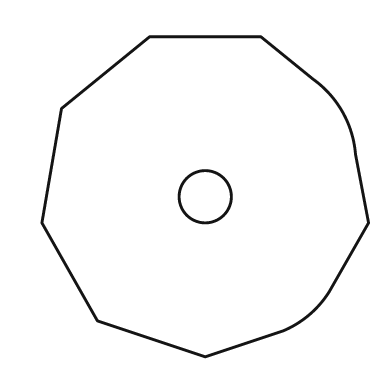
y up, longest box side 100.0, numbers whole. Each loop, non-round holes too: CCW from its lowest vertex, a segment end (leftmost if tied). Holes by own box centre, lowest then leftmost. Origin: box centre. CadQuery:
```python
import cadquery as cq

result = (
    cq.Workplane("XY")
    .moveTo(0.0, -49.0)
    .lineTo(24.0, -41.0)
    .threePointArc((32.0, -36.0), (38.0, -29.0))
    .lineTo(50.0, -8.0)
    .lineTo(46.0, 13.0)
    .threePointArc((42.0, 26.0), (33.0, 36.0))
    .lineTo(17.0, 49.0)
    .lineTo(-17.0, 49.0)
    .lineTo(-44.0, 27.0)
    .lineTo(-50.0, -8.0)
    .lineTo(-33.0, -38.0)
    .close()
    .moveTo(0.0, 0.0)
    .circle(8.0)
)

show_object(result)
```